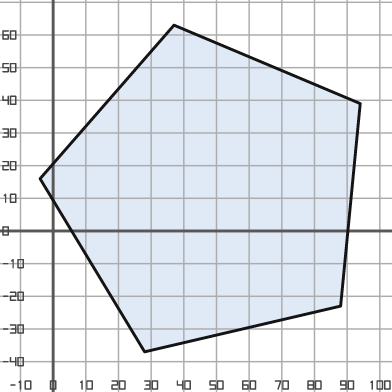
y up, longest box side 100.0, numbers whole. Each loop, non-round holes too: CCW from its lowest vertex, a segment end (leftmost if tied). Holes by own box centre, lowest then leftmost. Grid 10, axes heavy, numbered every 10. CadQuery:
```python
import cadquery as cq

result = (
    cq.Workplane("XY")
    .moveTo(28.0, -37.0)
    .lineTo(88.0, -23.0)
    .lineTo(94.0, 39.0)
    .lineTo(37.0, 63.0)
    .lineTo(-4.0, 16.0)
    .close()
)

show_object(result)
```